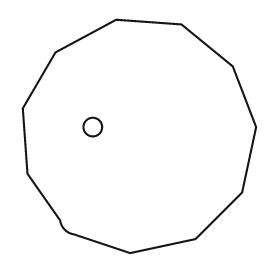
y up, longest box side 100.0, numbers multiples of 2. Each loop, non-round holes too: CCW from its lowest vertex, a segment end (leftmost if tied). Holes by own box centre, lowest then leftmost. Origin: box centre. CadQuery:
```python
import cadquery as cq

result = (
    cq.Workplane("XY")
    .moveTo(-4.0, -50.0)
    .lineTo(24.0, -44.0)
    .lineTo(44.0, -24.0)
    .lineTo(50.0, 4.0)
    .lineTo(40.0, 30.0)
    .lineTo(18.0, 48.0)
    .lineTo(-10.0, 50.0)
    .lineTo(-36.0, 36.0)
    .lineTo(-50.0, 12.0)
    .lineTo(-48.0, -16.0)
    .lineTo(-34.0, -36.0)
    .threePointArc((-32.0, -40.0), (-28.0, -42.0))
    .close()
    .moveTo(-20.0, 4.0)
    .circle(4.0)
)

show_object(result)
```